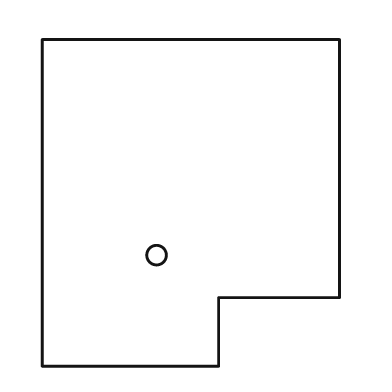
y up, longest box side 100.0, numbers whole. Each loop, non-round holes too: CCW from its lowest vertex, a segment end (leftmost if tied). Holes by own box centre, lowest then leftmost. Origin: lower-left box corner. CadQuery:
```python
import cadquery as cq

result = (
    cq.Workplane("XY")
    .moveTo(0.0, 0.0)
    .lineTo(54.0, 0.0)
    .lineTo(54.0, 21.0)
    .lineTo(91.0, 21.0)
    .lineTo(91.0, 100.0)
    .lineTo(0.0, 100.0)
    .close()
    .moveTo(35.0, 34.0)
    .circle(3.0)
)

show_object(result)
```